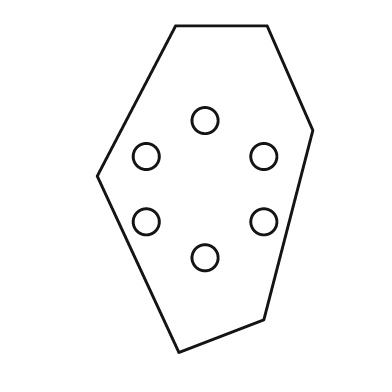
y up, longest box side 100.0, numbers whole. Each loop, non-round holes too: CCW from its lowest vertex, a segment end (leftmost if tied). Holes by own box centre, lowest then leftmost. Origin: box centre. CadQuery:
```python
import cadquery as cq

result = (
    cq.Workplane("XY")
    .moveTo(-8.0, -50.0)
    .lineTo(18.0, -40.0)
    .lineTo(33.0, 18.0)
    .lineTo(19.0, 50.0)
    .lineTo(-9.0, 50.0)
    .lineTo(-33.0, 4.0)
    .close()
    .moveTo(0.0, -21.0)
    .circle(4.0)
    .moveTo(-18.0, -10.0)
    .circle(4.0)
    .moveTo(18.0, -10.0)
    .circle(4.0)
    .moveTo(-18.0, 10.0)
    .circle(4.0)
    .moveTo(18.0, 10.0)
    .circle(4.0)
    .moveTo(0.0, 21.0)
    .circle(4.0)
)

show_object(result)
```